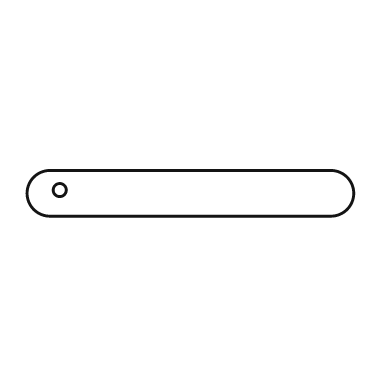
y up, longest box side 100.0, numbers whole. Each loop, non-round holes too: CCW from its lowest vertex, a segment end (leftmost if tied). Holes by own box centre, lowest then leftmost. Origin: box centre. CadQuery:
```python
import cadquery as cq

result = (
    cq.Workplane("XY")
    .moveTo(-43.0, -7.0)
    .lineTo(43.0, -7.0)
    .threePointArc((50.0, 0.0), (43.0, 7.0))
    .lineTo(-43.0, 7.0)
    .threePointArc((-50.0, 0.0), (-43.0, -7.0))
    .close()
    .moveTo(-40.0, 1.0)
    .circle(2.0)
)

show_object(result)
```